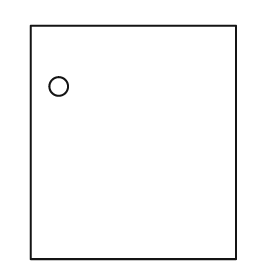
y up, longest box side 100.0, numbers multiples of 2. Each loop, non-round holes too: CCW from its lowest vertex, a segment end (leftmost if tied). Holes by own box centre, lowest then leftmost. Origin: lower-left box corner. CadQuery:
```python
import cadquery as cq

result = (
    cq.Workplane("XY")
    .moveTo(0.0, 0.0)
    .lineTo(88.0, 0.0)
    .lineTo(88.0, 100.0)
    .lineTo(0.0, 100.0)
    .close()
    .moveTo(12.0, 74.0)
    .circle(4.0)
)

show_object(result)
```